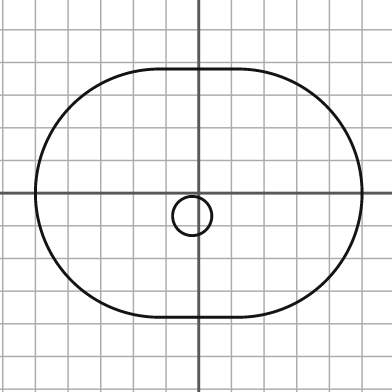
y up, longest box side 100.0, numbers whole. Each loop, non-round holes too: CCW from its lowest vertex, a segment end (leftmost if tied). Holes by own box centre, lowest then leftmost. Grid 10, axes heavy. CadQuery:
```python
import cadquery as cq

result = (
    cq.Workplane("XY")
    .moveTo(-12.0, -38.0)
    .lineTo(12.0, -38.0)
    .threePointArc((50.0, 0.0), (12.0, 38.0))
    .lineTo(-12.0, 38.0)
    .threePointArc((-50.0, 0.0), (-12.0, -38.0))
    .close()
    .moveTo(-2.0, -7.0)
    .circle(6.0)
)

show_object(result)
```